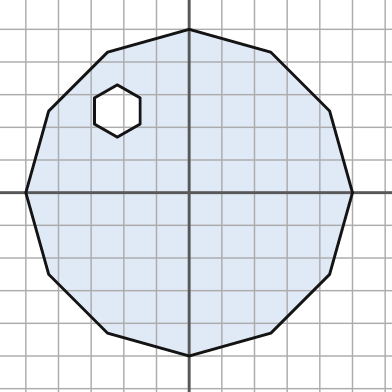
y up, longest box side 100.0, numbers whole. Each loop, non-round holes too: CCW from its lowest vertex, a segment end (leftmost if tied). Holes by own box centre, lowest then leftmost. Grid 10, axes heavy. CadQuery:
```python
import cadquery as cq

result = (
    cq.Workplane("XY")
    .moveTo(0.0, -50.0)
    .lineTo(25.0, -43.0)
    .lineTo(43.0, -25.0)
    .lineTo(50.0, 0.0)
    .lineTo(43.0, 25.0)
    .lineTo(25.0, 43.0)
    .lineTo(0.0, 50.0)
    .lineTo(-25.0, 43.0)
    .lineTo(-43.0, 25.0)
    .lineTo(-50.0, 0.0)
    .lineTo(-43.0, -25.0)
    .lineTo(-25.0, -43.0)
    .close()
    .moveTo(-22.0, 17.0)
    .lineTo(-15.0, 21.0)
    .lineTo(-15.0, 29.0)
    .lineTo(-22.0, 33.0)
    .lineTo(-29.0, 29.0)
    .lineTo(-29.0, 21.0)
    .close()
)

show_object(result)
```